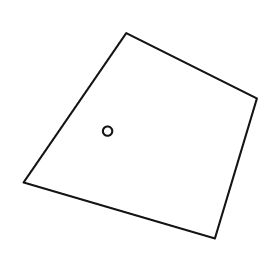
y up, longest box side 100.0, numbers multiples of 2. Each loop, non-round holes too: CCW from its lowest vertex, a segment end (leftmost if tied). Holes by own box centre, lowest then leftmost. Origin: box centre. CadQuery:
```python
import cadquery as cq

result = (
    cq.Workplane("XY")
    .moveTo(32.0, -44.0)
    .lineTo(50.0, 16.0)
    .lineTo(-6.0, 44.0)
    .lineTo(-50.0, -20.0)
    .close()
    .moveTo(-14.0, 2.0)
    .circle(2.0)
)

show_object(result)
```